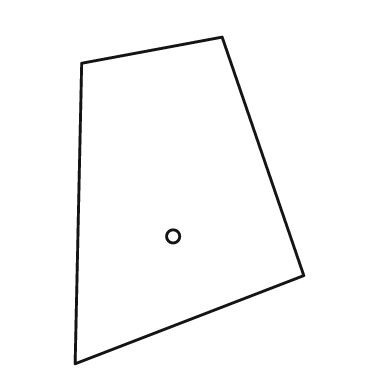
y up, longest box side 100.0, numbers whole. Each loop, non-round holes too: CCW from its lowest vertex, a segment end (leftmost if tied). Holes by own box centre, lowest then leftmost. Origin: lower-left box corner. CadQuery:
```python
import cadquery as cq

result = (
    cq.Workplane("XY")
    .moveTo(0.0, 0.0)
    .lineTo(70.0, 27.0)
    .lineTo(45.0, 100.0)
    .lineTo(2.0, 92.0)
    .close()
    .moveTo(30.0, 39.0)
    .circle(2.0)
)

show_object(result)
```